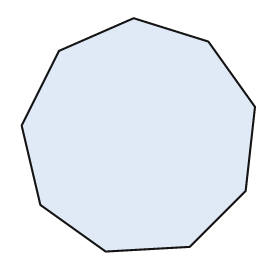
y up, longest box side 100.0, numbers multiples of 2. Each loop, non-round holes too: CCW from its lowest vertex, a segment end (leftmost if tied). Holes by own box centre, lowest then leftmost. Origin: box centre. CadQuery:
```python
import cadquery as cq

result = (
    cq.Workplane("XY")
    .moveTo(-14.0, -50.0)
    .lineTo(22.0, -48.0)
    .lineTo(46.0, -24.0)
    .lineTo(50.0, 12.0)
    .lineTo(30.0, 40.0)
    .lineTo(-2.0, 50.0)
    .lineTo(-34.0, 36.0)
    .lineTo(-50.0, 4.0)
    .lineTo(-42.0, -30.0)
    .close()
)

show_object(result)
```